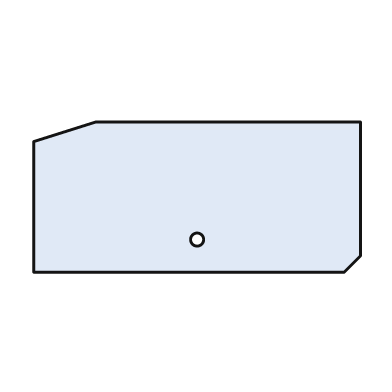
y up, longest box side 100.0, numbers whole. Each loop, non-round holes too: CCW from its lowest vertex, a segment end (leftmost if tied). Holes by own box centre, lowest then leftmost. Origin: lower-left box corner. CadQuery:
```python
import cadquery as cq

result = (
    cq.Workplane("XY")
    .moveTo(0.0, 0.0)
    .lineTo(95.0, 0.0)
    .lineTo(100.0, 5.0)
    .lineTo(100.0, 46.0)
    .lineTo(19.0, 46.0)
    .lineTo(0.0, 40.0)
    .close()
    .moveTo(50.0, 10.0)
    .circle(2.0)
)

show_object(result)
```